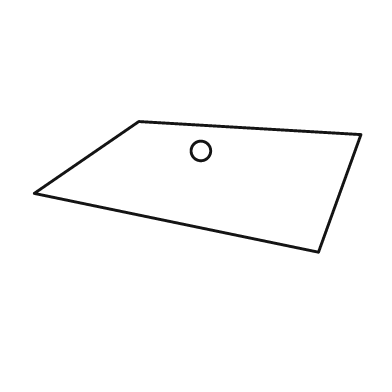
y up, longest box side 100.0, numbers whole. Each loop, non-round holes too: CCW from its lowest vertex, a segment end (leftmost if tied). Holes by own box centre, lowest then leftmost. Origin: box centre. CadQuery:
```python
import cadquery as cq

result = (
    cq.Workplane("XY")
    .moveTo(37.0, -20.0)
    .lineTo(50.0, 16.0)
    .lineTo(-18.0, 20.0)
    .lineTo(-50.0, -2.0)
    .close()
    .moveTo(1.0, 11.0)
    .circle(3.0)
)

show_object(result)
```